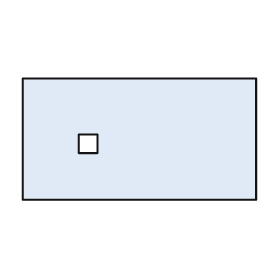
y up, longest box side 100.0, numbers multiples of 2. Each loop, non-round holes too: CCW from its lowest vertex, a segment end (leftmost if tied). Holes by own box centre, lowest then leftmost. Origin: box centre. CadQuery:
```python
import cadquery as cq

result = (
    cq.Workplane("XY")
    .moveTo(-50.0, -26.0)
    .lineTo(50.0, -26.0)
    .lineTo(50.0, 26.0)
    .lineTo(-50.0, 26.0)
    .close()
    .moveTo(-26.0, -6.0)
    .lineTo(-18.0, -6.0)
    .lineTo(-18.0, 2.0)
    .lineTo(-26.0, 2.0)
    .close()
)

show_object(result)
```